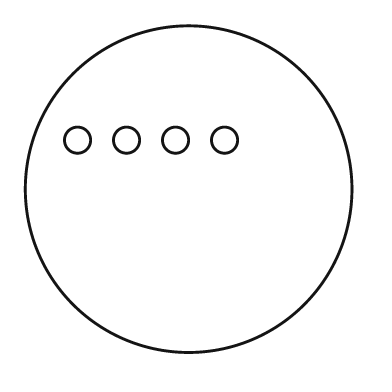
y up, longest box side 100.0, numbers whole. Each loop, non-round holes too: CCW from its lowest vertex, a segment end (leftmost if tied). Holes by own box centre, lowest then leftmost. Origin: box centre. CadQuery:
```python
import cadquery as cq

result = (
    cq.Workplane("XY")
    .moveTo(0.0, 0.0)
    .circle(50.0)
    .moveTo(-34.0, 15.0)
    .circle(4.0)
    .moveTo(-19.0, 15.0)
    .circle(4.0)
    .moveTo(-4.0, 15.0)
    .circle(4.0)
    .moveTo(11.0, 15.0)
    .circle(4.0)
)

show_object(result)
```